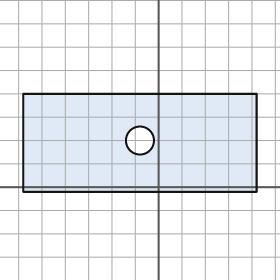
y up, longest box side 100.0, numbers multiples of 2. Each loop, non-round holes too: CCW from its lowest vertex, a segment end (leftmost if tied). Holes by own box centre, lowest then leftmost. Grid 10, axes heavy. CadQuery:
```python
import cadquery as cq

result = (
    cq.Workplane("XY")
    .moveTo(-58.0, -2.0)
    .lineTo(42.0, -2.0)
    .lineTo(42.0, 40.0)
    .lineTo(-58.0, 40.0)
    .close()
    .moveTo(-8.0, 20.0)
    .circle(6.0)
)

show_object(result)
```